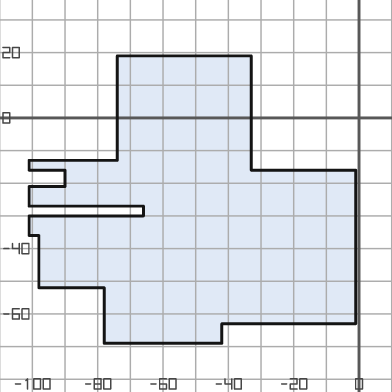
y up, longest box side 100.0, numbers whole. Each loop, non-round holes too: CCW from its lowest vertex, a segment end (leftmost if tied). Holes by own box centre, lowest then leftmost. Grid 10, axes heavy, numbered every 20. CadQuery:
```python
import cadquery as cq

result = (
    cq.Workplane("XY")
    .moveTo(-78.0, -69.0)
    .lineTo(-42.0, -69.0)
    .lineTo(-42.0, -63.0)
    .lineTo(-1.0, -63.0)
    .lineTo(-1.0, -16.0)
    .lineTo(-33.0, -16.0)
    .lineTo(-33.0, 19.0)
    .lineTo(-74.0, 19.0)
    .lineTo(-74.0, -13.0)
    .lineTo(-101.0, -13.0)
    .lineTo(-101.0, -16.0)
    .lineTo(-90.0, -16.0)
    .lineTo(-90.0, -21.0)
    .lineTo(-101.0, -21.0)
    .lineTo(-101.0, -27.0)
    .lineTo(-66.0, -27.0)
    .lineTo(-66.0, -30.0)
    .lineTo(-101.0, -30.0)
    .lineTo(-101.0, -36.0)
    .lineTo(-98.0, -36.0)
    .lineTo(-98.0, -52.0)
    .lineTo(-78.0, -52.0)
    .close()
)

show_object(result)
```